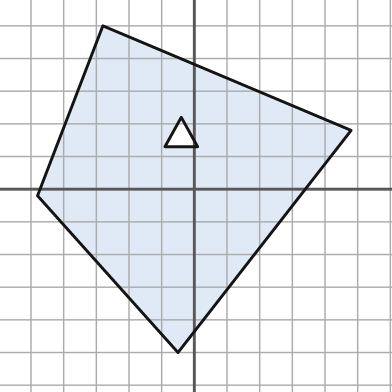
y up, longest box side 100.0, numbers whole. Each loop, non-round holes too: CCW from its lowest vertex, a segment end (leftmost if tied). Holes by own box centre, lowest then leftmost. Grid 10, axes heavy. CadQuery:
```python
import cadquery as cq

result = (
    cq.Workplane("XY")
    .moveTo(-5.0, -50.0)
    .lineTo(48.0, 18.0)
    .lineTo(-28.0, 50.0)
    .lineTo(-48.0, -2.0)
    .close()
    .moveTo(-9.0, 13.0)
    .lineTo(1.0, 13.0)
    .lineTo(-4.0, 22.0)
    .close()
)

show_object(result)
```